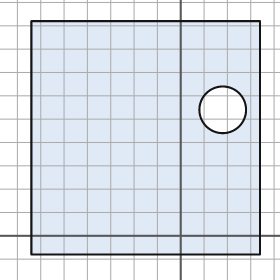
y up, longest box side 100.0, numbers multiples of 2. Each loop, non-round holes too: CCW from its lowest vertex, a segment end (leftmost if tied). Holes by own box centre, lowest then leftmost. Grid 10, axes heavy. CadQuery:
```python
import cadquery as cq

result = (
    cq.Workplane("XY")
    .moveTo(-64.0, -8.0)
    .lineTo(34.0, -8.0)
    .lineTo(34.0, 92.0)
    .lineTo(-64.0, 92.0)
    .close()
    .moveTo(18.0, 54.0)
    .circle(10.0)
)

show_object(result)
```